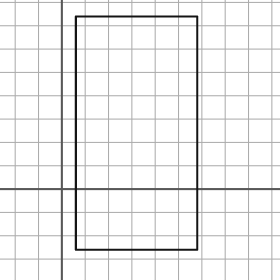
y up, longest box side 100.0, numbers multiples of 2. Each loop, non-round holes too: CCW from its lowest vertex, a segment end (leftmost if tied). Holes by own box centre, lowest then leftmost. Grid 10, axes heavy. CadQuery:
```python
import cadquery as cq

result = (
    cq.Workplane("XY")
    .moveTo(6.0, -26.0)
    .lineTo(58.0, -26.0)
    .lineTo(58.0, 74.0)
    .lineTo(6.0, 74.0)
    .close()
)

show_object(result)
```